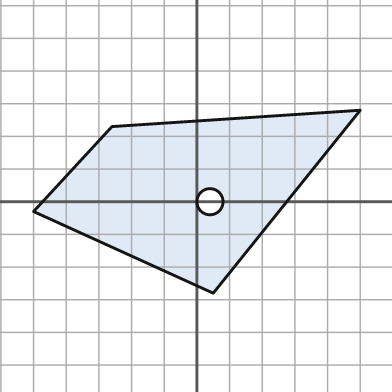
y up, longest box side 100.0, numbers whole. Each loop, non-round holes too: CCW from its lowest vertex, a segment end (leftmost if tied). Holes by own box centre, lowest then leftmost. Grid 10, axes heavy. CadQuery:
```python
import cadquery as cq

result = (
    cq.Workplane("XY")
    .moveTo(5.0, -28.0)
    .lineTo(50.0, 28.0)
    .lineTo(-26.0, 23.0)
    .lineTo(-50.0, -3.0)
    .close()
    .moveTo(4.0, 0.0)
    .circle(4.0)
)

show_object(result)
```